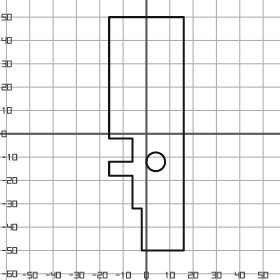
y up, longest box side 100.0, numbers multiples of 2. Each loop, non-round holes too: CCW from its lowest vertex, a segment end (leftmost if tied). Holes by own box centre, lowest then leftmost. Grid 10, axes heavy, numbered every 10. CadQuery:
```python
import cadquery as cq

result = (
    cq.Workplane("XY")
    .moveTo(-2.0, -50.0)
    .lineTo(16.0, -50.0)
    .lineTo(16.0, 50.0)
    .lineTo(-16.0, 50.0)
    .lineTo(-16.0, -2.0)
    .lineTo(-6.0, -2.0)
    .lineTo(-6.0, -12.0)
    .lineTo(-16.0, -12.0)
    .lineTo(-16.0, -18.0)
    .lineTo(-6.0, -18.0)
    .lineTo(-6.0, -32.0)
    .lineTo(-2.0, -32.0)
    .close()
    .moveTo(4.0, -12.0)
    .circle(4.0)
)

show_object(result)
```